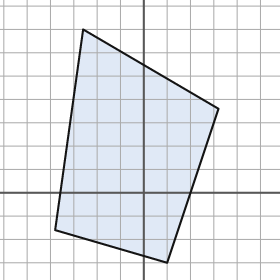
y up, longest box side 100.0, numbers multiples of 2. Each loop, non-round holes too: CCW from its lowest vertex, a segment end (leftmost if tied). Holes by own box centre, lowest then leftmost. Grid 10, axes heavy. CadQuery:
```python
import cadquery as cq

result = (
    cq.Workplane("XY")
    .moveTo(10.0, -30.0)
    .lineTo(32.0, 36.0)
    .lineTo(-26.0, 70.0)
    .lineTo(-38.0, -16.0)
    .close()
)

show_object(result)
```